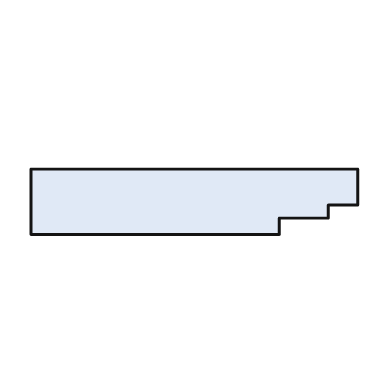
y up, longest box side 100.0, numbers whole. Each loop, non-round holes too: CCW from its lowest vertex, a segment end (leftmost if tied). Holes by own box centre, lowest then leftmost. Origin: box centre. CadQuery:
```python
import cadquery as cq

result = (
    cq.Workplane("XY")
    .moveTo(-50.0, -10.0)
    .lineTo(26.0, -10.0)
    .lineTo(26.0, -5.0)
    .lineTo(41.0, -5.0)
    .lineTo(41.0, -1.0)
    .lineTo(50.0, -1.0)
    .lineTo(50.0, 10.0)
    .lineTo(-50.0, 10.0)
    .close()
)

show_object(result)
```